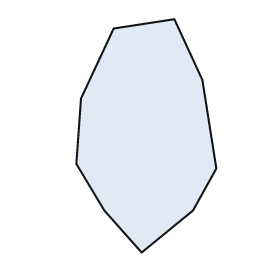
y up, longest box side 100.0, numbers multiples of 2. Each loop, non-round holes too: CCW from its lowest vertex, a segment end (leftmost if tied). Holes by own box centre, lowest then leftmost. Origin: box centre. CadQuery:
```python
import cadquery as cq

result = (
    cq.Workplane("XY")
    .moveTo(-2.0, -50.0)
    .lineTo(20.0, -32.0)
    .lineTo(30.0, -14.0)
    .lineTo(24.0, 24.0)
    .lineTo(12.0, 50.0)
    .lineTo(-14.0, 46.0)
    .lineTo(-28.0, 16.0)
    .lineTo(-30.0, -12.0)
    .lineTo(-18.0, -32.0)
    .close()
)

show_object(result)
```